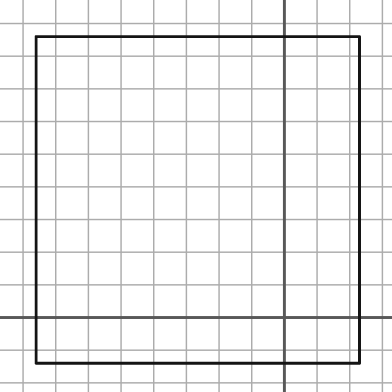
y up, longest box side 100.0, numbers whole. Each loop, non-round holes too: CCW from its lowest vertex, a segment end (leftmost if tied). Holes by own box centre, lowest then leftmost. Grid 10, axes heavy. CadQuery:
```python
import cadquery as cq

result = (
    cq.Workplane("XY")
    .moveTo(-76.0, -14.0)
    .lineTo(23.0, -14.0)
    .lineTo(23.0, 86.0)
    .lineTo(-76.0, 86.0)
    .close()
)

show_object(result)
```